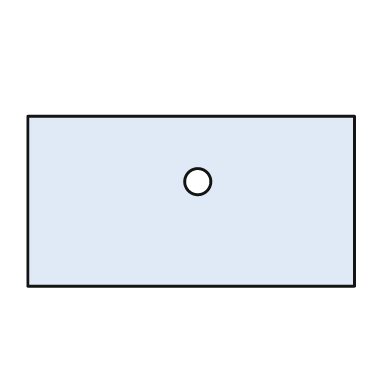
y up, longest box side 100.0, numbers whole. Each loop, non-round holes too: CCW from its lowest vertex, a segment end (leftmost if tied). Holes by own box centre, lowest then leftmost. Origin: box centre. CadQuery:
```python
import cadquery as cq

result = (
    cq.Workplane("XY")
    .moveTo(-50.0, -26.0)
    .lineTo(50.0, -26.0)
    .lineTo(50.0, 26.0)
    .lineTo(-50.0, 26.0)
    .close()
    .moveTo(2.0, 6.0)
    .circle(4.0)
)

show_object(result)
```